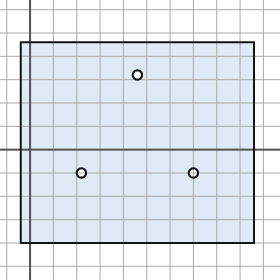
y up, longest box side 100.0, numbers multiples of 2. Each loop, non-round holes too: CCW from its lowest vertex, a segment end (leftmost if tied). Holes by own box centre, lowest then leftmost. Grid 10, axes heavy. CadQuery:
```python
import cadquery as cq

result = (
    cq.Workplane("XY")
    .moveTo(-4.0, -40.0)
    .lineTo(96.0, -40.0)
    .lineTo(96.0, 46.0)
    .lineTo(-4.0, 46.0)
    .close()
    .moveTo(22.0, -10.0)
    .circle(2.0)
    .moveTo(70.0, -10.0)
    .circle(2.0)
    .moveTo(46.0, 32.0)
    .circle(2.0)
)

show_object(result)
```